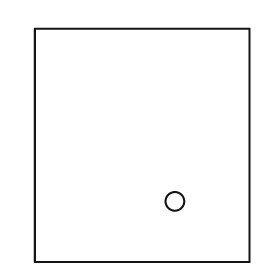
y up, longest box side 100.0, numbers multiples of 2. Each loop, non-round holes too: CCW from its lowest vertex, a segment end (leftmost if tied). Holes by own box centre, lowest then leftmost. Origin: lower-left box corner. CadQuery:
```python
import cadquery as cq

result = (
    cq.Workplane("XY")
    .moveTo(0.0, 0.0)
    .lineTo(92.0, 0.0)
    .lineTo(92.0, 100.0)
    .lineTo(0.0, 100.0)
    .close()
    .moveTo(60.0, 26.0)
    .circle(4.0)
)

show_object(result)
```